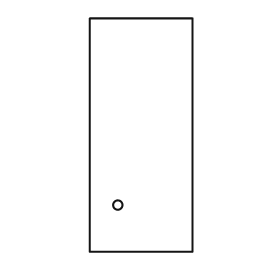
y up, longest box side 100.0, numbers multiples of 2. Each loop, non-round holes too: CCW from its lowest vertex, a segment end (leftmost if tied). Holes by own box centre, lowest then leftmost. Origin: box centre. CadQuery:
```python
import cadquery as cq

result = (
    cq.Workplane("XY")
    .moveTo(-22.0, -50.0)
    .lineTo(22.0, -50.0)
    .lineTo(22.0, 50.0)
    .lineTo(-22.0, 50.0)
    .close()
    .moveTo(-10.0, -30.0)
    .circle(2.0)
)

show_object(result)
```